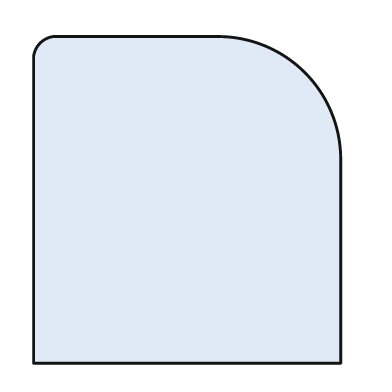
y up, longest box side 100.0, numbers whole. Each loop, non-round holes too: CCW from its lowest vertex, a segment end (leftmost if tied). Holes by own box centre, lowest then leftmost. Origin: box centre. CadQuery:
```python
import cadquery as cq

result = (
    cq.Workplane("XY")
    .moveTo(-47.0, -50.0)
    .lineTo(47.0, -50.0)
    .lineTo(47.0, 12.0)
    .threePointArc((36.0, 39.0), (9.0, 50.0))
    .lineTo(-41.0, 50.0)
    .threePointArc((-45.0, 48.0), (-47.0, 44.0))
    .close()
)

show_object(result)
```